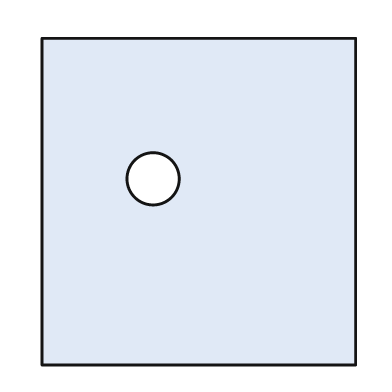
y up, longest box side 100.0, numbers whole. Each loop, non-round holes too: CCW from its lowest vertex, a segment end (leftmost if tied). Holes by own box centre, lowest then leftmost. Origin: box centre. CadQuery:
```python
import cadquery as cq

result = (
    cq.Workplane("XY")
    .moveTo(-48.0, -50.0)
    .lineTo(48.0, -50.0)
    .lineTo(48.0, 50.0)
    .lineTo(-48.0, 50.0)
    .close()
    .moveTo(-14.0, 7.0)
    .circle(8.0)
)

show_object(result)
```